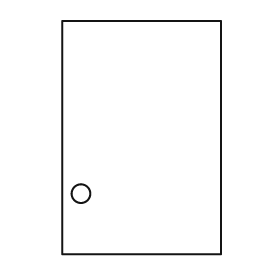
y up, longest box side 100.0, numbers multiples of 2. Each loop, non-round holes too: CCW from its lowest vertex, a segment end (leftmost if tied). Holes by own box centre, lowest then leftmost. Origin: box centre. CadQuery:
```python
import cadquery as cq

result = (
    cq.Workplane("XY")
    .moveTo(-34.0, -50.0)
    .lineTo(34.0, -50.0)
    .lineTo(34.0, 50.0)
    .lineTo(-34.0, 50.0)
    .close()
    .moveTo(-26.0, -24.0)
    .circle(4.0)
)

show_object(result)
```